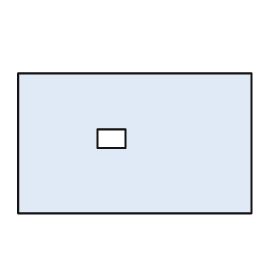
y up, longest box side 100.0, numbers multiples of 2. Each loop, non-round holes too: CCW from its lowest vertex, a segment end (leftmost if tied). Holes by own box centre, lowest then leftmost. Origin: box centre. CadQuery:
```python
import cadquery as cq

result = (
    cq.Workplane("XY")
    .moveTo(-50.0, -30.0)
    .lineTo(50.0, -30.0)
    .lineTo(50.0, 30.0)
    .lineTo(-50.0, 30.0)
    .close()
    .moveTo(-16.0, -2.0)
    .lineTo(-4.0, -2.0)
    .lineTo(-4.0, 6.0)
    .lineTo(-16.0, 6.0)
    .close()
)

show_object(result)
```